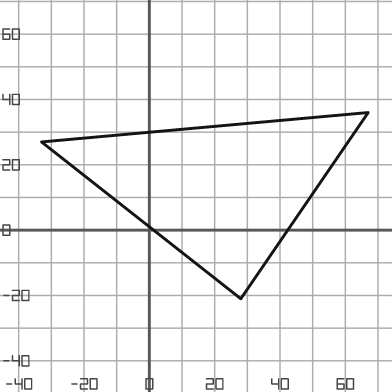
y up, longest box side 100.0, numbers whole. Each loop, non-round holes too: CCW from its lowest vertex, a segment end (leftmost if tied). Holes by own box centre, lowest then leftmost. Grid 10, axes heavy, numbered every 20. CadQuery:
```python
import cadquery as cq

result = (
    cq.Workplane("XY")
    .moveTo(28.0, -21.0)
    .lineTo(67.0, 36.0)
    .lineTo(-33.0, 27.0)
    .close()
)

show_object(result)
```